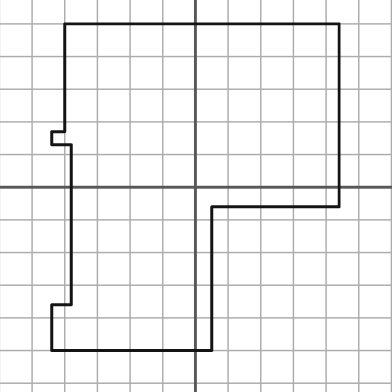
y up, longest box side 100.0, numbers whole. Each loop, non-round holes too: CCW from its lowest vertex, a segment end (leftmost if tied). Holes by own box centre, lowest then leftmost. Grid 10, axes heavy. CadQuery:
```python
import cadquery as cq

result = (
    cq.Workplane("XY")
    .moveTo(-44.0, -50.0)
    .lineTo(5.0, -50.0)
    .lineTo(5.0, -6.0)
    .lineTo(44.0, -6.0)
    .lineTo(44.0, 50.0)
    .lineTo(-40.0, 50.0)
    .lineTo(-40.0, 17.0)
    .lineTo(-44.0, 17.0)
    .lineTo(-44.0, 13.0)
    .lineTo(-38.0, 13.0)
    .lineTo(-38.0, -36.0)
    .lineTo(-44.0, -36.0)
    .close()
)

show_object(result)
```